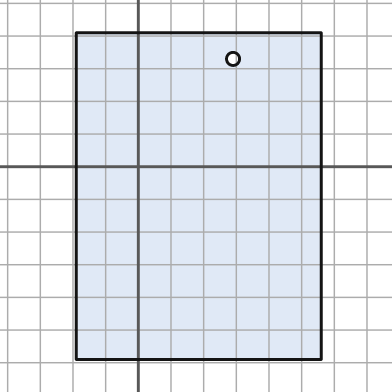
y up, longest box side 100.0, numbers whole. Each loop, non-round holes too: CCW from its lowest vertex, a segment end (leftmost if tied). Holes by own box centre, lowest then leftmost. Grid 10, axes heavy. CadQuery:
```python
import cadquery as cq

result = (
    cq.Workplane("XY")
    .moveTo(-19.0, -59.0)
    .lineTo(56.0, -59.0)
    .lineTo(56.0, 41.0)
    .lineTo(-19.0, 41.0)
    .close()
    .moveTo(29.0, 33.0)
    .circle(2.0)
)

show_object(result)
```